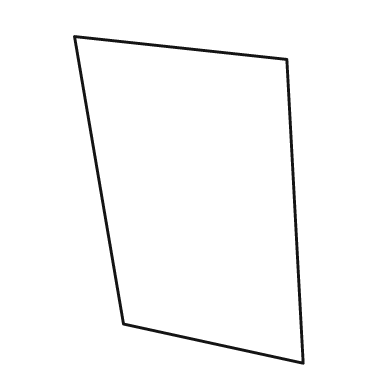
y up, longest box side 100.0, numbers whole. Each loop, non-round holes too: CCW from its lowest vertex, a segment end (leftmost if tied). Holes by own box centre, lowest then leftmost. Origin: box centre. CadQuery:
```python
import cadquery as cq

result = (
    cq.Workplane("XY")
    .moveTo(35.0, -50.0)
    .lineTo(30.0, 43.0)
    .lineTo(-35.0, 50.0)
    .lineTo(-20.0, -38.0)
    .close()
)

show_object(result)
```